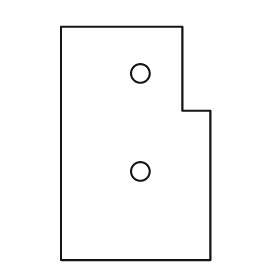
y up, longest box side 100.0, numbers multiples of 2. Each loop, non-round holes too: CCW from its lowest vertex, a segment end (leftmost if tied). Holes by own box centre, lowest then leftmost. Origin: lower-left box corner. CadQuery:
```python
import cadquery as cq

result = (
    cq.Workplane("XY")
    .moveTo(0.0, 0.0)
    .lineTo(64.0, 0.0)
    .lineTo(64.0, 64.0)
    .lineTo(52.0, 64.0)
    .lineTo(52.0, 100.0)
    .lineTo(0.0, 100.0)
    .close()
    .moveTo(34.0, 38.0)
    .circle(4.0)
    .moveTo(34.0, 80.0)
    .circle(4.0)
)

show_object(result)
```